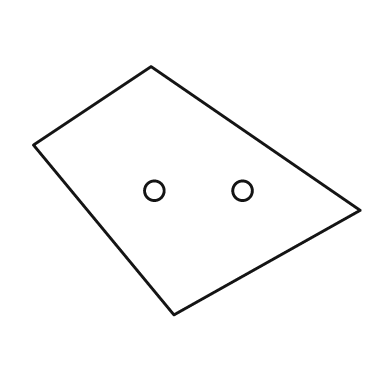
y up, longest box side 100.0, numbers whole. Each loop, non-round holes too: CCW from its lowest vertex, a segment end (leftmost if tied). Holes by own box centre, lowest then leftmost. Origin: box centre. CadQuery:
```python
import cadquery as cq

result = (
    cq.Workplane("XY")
    .moveTo(-7.0, -38.0)
    .lineTo(50.0, -6.0)
    .lineTo(-14.0, 38.0)
    .lineTo(-50.0, 14.0)
    .close()
    .moveTo(-13.0, 0.0)
    .circle(3.0)
    .moveTo(14.0, 0.0)
    .circle(3.0)
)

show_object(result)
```